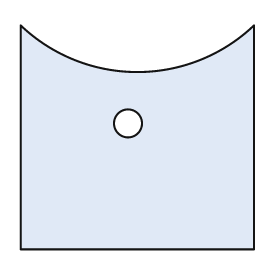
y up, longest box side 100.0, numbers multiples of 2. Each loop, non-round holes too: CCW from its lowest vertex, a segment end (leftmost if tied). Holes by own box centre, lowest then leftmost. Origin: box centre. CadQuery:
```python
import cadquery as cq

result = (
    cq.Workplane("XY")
    .moveTo(-50.0, -48.0)
    .lineTo(50.0, -48.0)
    .lineTo(50.0, 48.0)
    .threePointArc((0.0, 28.0), (-50.0, 48.0))
    .close()
    .moveTo(-4.0, 6.0)
    .circle(6.0)
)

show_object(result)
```